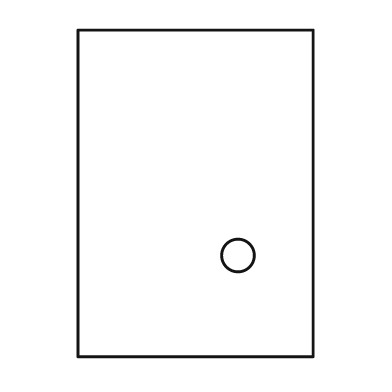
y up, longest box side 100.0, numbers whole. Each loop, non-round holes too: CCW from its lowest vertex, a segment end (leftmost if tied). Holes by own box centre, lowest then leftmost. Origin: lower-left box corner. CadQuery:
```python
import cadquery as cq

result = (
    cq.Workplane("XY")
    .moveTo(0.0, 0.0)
    .lineTo(72.0, 0.0)
    .lineTo(72.0, 100.0)
    .lineTo(0.0, 100.0)
    .close()
    .moveTo(49.0, 31.0)
    .circle(5.0)
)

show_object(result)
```